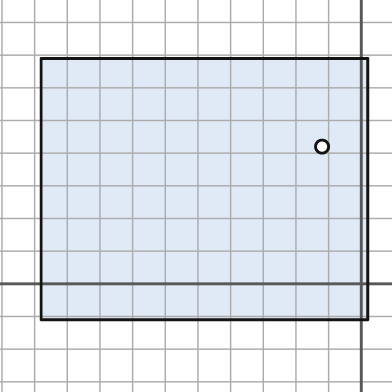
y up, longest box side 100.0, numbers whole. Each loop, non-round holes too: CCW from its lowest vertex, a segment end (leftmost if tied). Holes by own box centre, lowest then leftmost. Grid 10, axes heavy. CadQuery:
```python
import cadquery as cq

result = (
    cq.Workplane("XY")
    .moveTo(-98.0, -11.0)
    .lineTo(2.0, -11.0)
    .lineTo(2.0, 69.0)
    .lineTo(-98.0, 69.0)
    .close()
    .moveTo(-12.0, 42.0)
    .circle(2.0)
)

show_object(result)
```